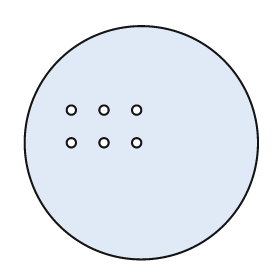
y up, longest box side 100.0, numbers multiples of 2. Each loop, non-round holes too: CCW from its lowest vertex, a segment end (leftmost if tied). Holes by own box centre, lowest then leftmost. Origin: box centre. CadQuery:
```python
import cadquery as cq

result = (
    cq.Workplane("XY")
    .moveTo(0.0, 0.0)
    .circle(50.0)
    .moveTo(-30.0, 0.0)
    .circle(2.0)
    .moveTo(-16.0, 0.0)
    .circle(2.0)
    .moveTo(-2.0, 0.0)
    .circle(2.0)
    .moveTo(-30.0, 14.0)
    .circle(2.0)
    .moveTo(-16.0, 14.0)
    .circle(2.0)
    .moveTo(-2.0, 14.0)
    .circle(2.0)
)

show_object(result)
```